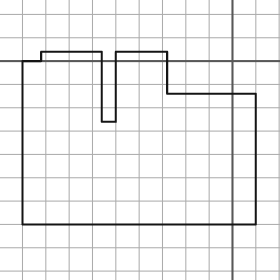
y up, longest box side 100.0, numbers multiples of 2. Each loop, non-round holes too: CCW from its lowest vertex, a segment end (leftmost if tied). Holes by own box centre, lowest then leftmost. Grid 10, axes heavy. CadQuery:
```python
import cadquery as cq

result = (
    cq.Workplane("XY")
    .moveTo(-90.0, -70.0)
    .lineTo(10.0, -70.0)
    .lineTo(10.0, -14.0)
    .lineTo(-28.0, -14.0)
    .lineTo(-28.0, 4.0)
    .lineTo(-50.0, 4.0)
    .lineTo(-50.0, -26.0)
    .lineTo(-56.0, -26.0)
    .lineTo(-56.0, 4.0)
    .lineTo(-82.0, 4.0)
    .lineTo(-82.0, 0.0)
    .lineTo(-90.0, 0.0)
    .close()
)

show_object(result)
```